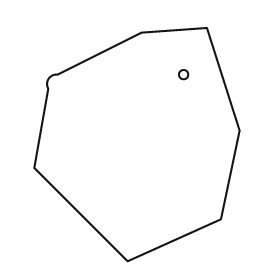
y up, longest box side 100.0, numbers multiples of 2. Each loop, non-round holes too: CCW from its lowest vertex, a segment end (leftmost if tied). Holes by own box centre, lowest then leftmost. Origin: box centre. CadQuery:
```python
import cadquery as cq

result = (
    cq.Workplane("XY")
    .moveTo(-4.0, -50.0)
    .lineTo(36.0, -32.0)
    .lineTo(44.0, 6.0)
    .lineTo(30.0, 50.0)
    .lineTo(2.0, 48.0)
    .lineTo(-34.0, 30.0)
    .threePointArc((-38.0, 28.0), (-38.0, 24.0))
    .lineTo(-44.0, -10.0)
    .close()
    .moveTo(20.0, 30.0)
    .circle(2.0)
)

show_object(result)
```